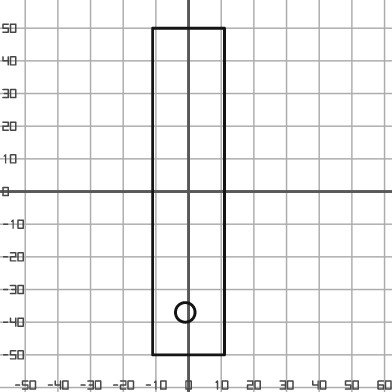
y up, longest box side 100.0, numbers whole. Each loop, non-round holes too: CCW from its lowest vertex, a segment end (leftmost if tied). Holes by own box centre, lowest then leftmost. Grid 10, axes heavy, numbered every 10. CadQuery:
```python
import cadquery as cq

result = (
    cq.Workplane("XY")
    .moveTo(-11.0, -50.0)
    .lineTo(11.0, -50.0)
    .lineTo(11.0, 50.0)
    .lineTo(-11.0, 50.0)
    .close()
    .moveTo(-1.0, -37.0)
    .circle(3.0)
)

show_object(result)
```